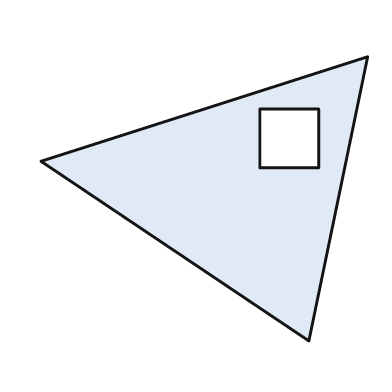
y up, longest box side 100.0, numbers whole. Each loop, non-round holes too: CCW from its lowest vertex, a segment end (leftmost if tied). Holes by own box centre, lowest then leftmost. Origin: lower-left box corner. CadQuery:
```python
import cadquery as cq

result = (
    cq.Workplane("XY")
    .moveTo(82.0, 0.0)
    .lineTo(100.0, 87.0)
    .lineTo(0.0, 55.0)
    .close()
    .moveTo(67.0, 53.0)
    .lineTo(85.0, 53.0)
    .lineTo(85.0, 71.0)
    .lineTo(67.0, 71.0)
    .close()
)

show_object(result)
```